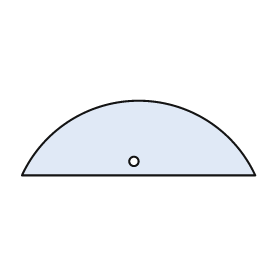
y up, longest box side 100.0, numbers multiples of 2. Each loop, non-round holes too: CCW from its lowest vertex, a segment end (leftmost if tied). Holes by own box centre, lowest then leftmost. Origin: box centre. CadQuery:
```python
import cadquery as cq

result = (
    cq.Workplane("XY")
    .moveTo(-50.0, -16.0)
    .lineTo(50.0, -16.0)
    .threePointArc((0.0, 16.0), (-50.0, -16.0))
    .close()
    .moveTo(-2.0, -10.0)
    .circle(2.0)
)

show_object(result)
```